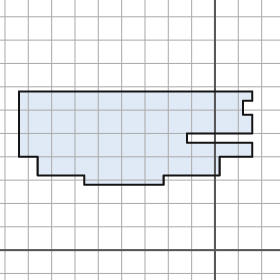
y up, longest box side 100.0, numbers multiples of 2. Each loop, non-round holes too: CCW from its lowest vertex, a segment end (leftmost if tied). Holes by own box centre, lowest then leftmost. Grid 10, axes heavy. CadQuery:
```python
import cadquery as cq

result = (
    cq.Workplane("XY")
    .moveTo(-56.0, 28.0)
    .lineTo(-22.0, 28.0)
    .lineTo(-22.0, 32.0)
    .lineTo(2.0, 32.0)
    .lineTo(2.0, 40.0)
    .lineTo(16.0, 40.0)
    .lineTo(16.0, 46.0)
    .lineTo(-12.0, 46.0)
    .lineTo(-12.0, 50.0)
    .lineTo(16.0, 50.0)
    .lineTo(16.0, 58.0)
    .lineTo(12.0, 58.0)
    .lineTo(12.0, 64.0)
    .lineTo(16.0, 64.0)
    .lineTo(16.0, 68.0)
    .lineTo(-84.0, 68.0)
    .lineTo(-84.0, 40.0)
    .lineTo(-76.0, 40.0)
    .lineTo(-76.0, 32.0)
    .lineTo(-56.0, 32.0)
    .close()
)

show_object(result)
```